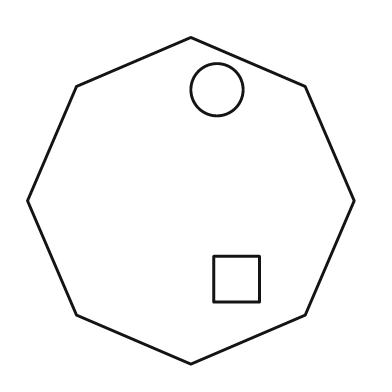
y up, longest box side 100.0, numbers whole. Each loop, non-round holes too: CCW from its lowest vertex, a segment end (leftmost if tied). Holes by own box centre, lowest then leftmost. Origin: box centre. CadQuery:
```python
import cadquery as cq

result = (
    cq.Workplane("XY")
    .moveTo(0.0, -50.0)
    .lineTo(35.0, -35.0)
    .lineTo(50.0, 0.0)
    .lineTo(35.0, 35.0)
    .lineTo(0.0, 50.0)
    .lineTo(-35.0, 35.0)
    .lineTo(-50.0, 0.0)
    .lineTo(-35.0, -35.0)
    .close()
    .moveTo(7.0, -31.0)
    .lineTo(21.0, -31.0)
    .lineTo(21.0, -17.0)
    .lineTo(7.0, -17.0)
    .close()
    .moveTo(8.0, 34.0)
    .circle(8.0)
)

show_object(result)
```